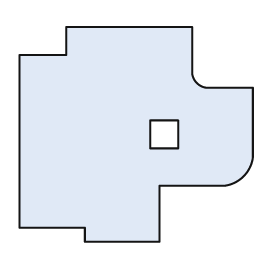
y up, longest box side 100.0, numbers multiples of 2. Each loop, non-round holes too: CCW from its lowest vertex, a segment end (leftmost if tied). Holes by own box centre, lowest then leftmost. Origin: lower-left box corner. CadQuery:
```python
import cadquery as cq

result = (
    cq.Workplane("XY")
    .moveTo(28.0, 0.0)
    .lineTo(60.0, 0.0)
    .lineTo(60.0, 24.0)
    .lineTo(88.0, 24.0)
    .threePointArc((96.0, 28.0), (100.0, 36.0))
    .lineTo(100.0, 66.0)
    .lineTo(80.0, 66.0)
    .threePointArc((76.0, 68.0), (74.0, 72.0))
    .lineTo(74.0, 92.0)
    .lineTo(20.0, 92.0)
    .lineTo(20.0, 80.0)
    .lineTo(0.0, 80.0)
    .lineTo(0.0, 6.0)
    .lineTo(28.0, 6.0)
    .close()
    .moveTo(56.0, 40.0)
    .lineTo(68.0, 40.0)
    .lineTo(68.0, 52.0)
    .lineTo(56.0, 52.0)
    .close()
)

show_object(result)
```